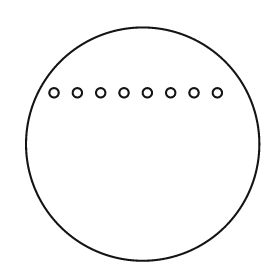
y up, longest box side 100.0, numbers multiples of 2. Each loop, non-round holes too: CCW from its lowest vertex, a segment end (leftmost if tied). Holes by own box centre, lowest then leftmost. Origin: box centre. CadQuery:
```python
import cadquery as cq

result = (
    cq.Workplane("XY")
    .moveTo(0.0, 0.0)
    .circle(50.0)
    .moveTo(-38.0, 22.0)
    .circle(2.0)
    .moveTo(-28.0, 22.0)
    .circle(2.0)
    .moveTo(-18.0, 22.0)
    .circle(2.0)
    .moveTo(-8.0, 22.0)
    .circle(2.0)
    .moveTo(2.0, 22.0)
    .circle(2.0)
    .moveTo(12.0, 22.0)
    .circle(2.0)
    .moveTo(22.0, 22.0)
    .circle(2.0)
    .moveTo(32.0, 22.0)
    .circle(2.0)
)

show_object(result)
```